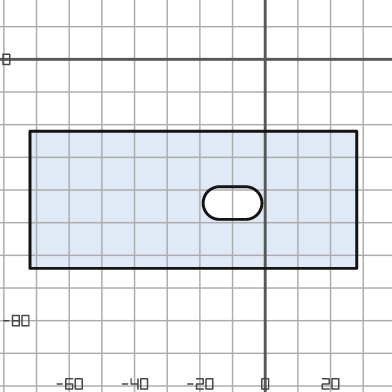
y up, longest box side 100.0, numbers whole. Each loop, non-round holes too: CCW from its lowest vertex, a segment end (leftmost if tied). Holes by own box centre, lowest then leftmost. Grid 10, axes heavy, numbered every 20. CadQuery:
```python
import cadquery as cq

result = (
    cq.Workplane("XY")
    .moveTo(-72.0, -64.0)
    .lineTo(28.0, -64.0)
    .lineTo(28.0, -22.0)
    .lineTo(-72.0, -22.0)
    .close()
    .moveTo(-14.0, -49.0)
    .lineTo(-6.0, -49.0)
    .threePointArc((-1.0, -44.0), (-6.0, -39.0))
    .lineTo(-14.0, -39.0)
    .threePointArc((-19.0, -44.0), (-14.0, -49.0))
    .close()
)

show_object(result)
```